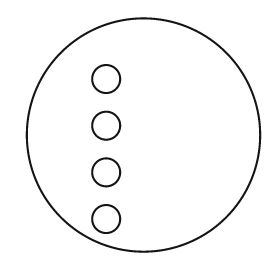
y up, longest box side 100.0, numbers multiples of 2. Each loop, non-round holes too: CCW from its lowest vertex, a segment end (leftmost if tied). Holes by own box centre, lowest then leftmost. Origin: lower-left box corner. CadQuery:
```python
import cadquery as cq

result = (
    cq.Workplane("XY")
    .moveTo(50.0, 50.0)
    .circle(50.0)
    .moveTo(34.0, 14.0)
    .circle(6.0)
    .moveTo(34.0, 34.0)
    .circle(6.0)
    .moveTo(34.0, 54.0)
    .circle(6.0)
    .moveTo(34.0, 74.0)
    .circle(6.0)
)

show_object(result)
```